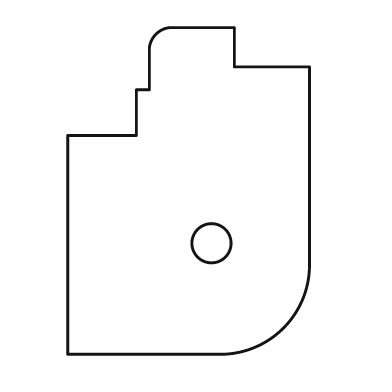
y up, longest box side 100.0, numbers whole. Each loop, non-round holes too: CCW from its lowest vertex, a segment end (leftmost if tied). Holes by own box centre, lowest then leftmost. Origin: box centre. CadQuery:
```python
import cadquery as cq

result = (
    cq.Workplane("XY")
    .moveTo(-37.0, -50.0)
    .lineTo(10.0, -50.0)
    .threePointArc((29.0, -42.0), (37.0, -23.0))
    .lineTo(37.0, 38.0)
    .lineTo(14.0, 38.0)
    .lineTo(14.0, 50.0)
    .lineTo(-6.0, 50.0)
    .threePointArc((-10.0, 48.0), (-12.0, 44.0))
    .lineTo(-12.0, 31.0)
    .lineTo(-16.0, 31.0)
    .lineTo(-16.0, 17.0)
    .lineTo(-37.0, 17.0)
    .close()
    .moveTo(7.0, -16.0)
    .circle(6.0)
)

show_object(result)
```